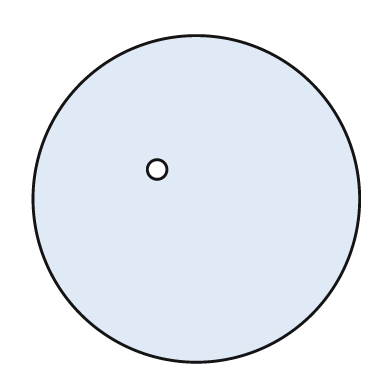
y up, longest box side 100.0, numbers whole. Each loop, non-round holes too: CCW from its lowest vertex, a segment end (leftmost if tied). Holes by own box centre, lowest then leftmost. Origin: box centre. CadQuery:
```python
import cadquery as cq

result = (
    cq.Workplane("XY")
    .moveTo(0.0, 0.0)
    .circle(50.0)
    .moveTo(-12.0, 9.0)
    .circle(3.0)
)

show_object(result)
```